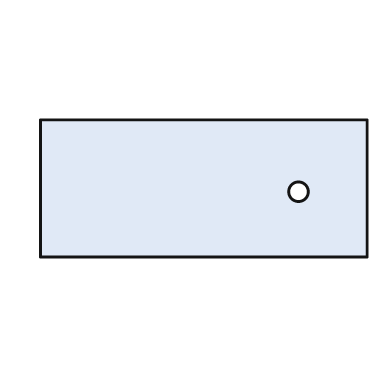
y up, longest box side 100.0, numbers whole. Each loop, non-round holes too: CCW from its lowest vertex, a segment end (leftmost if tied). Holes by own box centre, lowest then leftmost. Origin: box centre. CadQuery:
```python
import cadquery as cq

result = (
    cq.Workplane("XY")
    .moveTo(-50.0, -21.0)
    .lineTo(50.0, -21.0)
    .lineTo(50.0, 21.0)
    .lineTo(-50.0, 21.0)
    .close()
    .moveTo(29.0, -1.0)
    .circle(3.0)
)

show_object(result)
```